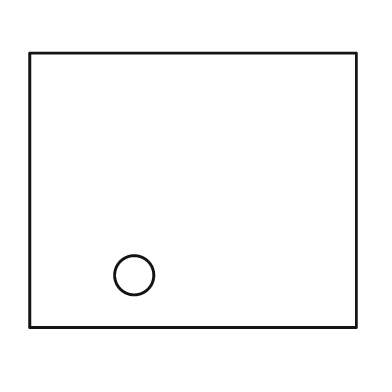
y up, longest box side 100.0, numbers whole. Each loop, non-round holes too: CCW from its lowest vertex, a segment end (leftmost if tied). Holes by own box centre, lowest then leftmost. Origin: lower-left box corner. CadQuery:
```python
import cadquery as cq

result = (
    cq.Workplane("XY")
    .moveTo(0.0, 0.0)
    .lineTo(100.0, 0.0)
    .lineTo(100.0, 84.0)
    .lineTo(0.0, 84.0)
    .close()
    .moveTo(32.0, 16.0)
    .circle(6.0)
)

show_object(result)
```